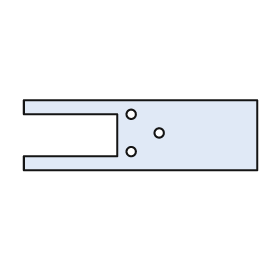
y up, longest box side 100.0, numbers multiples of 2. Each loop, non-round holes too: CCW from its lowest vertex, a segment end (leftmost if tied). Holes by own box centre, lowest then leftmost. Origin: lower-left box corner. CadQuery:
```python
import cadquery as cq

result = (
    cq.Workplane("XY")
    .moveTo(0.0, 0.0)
    .lineTo(100.0, 0.0)
    .lineTo(100.0, 30.0)
    .lineTo(0.0, 30.0)
    .lineTo(0.0, 24.0)
    .lineTo(40.0, 24.0)
    .lineTo(40.0, 6.0)
    .lineTo(0.0, 6.0)
    .close()
    .moveTo(46.0, 8.0)
    .circle(2.0)
    .moveTo(58.0, 16.0)
    .circle(2.0)
    .moveTo(46.0, 24.0)
    .circle(2.0)
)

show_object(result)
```